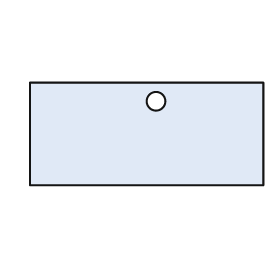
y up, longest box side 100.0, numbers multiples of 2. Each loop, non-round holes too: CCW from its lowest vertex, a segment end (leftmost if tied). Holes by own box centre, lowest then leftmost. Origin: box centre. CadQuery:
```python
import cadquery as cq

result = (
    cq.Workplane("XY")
    .moveTo(-50.0, -22.0)
    .lineTo(50.0, -22.0)
    .lineTo(50.0, 22.0)
    .lineTo(-50.0, 22.0)
    .close()
    .moveTo(4.0, 14.0)
    .circle(4.0)
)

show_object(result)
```